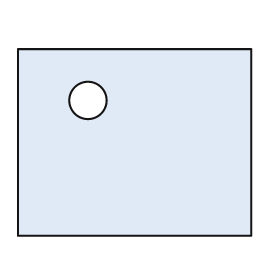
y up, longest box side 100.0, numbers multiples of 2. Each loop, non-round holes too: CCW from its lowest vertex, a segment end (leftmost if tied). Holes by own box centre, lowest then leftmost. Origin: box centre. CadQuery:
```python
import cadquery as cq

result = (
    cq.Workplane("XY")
    .moveTo(-50.0, -40.0)
    .lineTo(50.0, -40.0)
    .lineTo(50.0, 40.0)
    .lineTo(-50.0, 40.0)
    .close()
    .moveTo(-20.0, 18.0)
    .circle(8.0)
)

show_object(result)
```